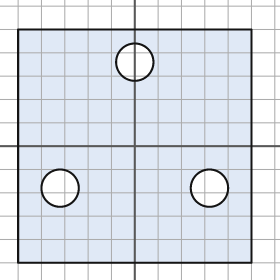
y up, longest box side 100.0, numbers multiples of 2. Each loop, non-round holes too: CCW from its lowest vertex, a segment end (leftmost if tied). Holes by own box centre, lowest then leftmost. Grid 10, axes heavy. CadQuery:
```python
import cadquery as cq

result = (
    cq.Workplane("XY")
    .moveTo(-50.0, -50.0)
    .lineTo(50.0, -50.0)
    .lineTo(50.0, 50.0)
    .lineTo(-50.0, 50.0)
    .close()
    .moveTo(-32.0, -18.0)
    .circle(8.0)
    .moveTo(32.0, -18.0)
    .circle(8.0)
    .moveTo(0.0, 36.0)
    .circle(8.0)
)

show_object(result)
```